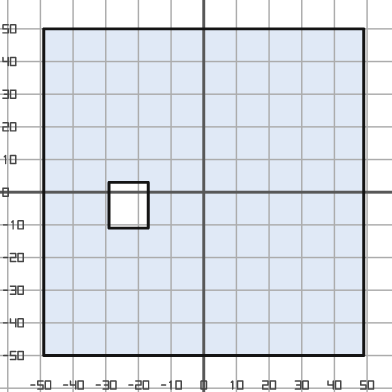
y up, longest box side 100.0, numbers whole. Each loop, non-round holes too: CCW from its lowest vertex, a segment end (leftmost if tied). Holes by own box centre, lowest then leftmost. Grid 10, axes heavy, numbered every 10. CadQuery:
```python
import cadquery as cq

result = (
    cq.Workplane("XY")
    .moveTo(-49.0, -50.0)
    .lineTo(49.0, -50.0)
    .lineTo(49.0, 50.0)
    .lineTo(-49.0, 50.0)
    .close()
    .moveTo(-29.0, -11.0)
    .lineTo(-17.0, -11.0)
    .lineTo(-17.0, 3.0)
    .lineTo(-29.0, 3.0)
    .close()
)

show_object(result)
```